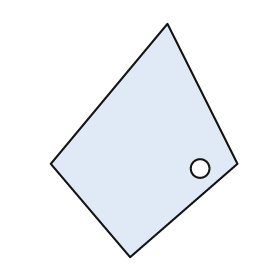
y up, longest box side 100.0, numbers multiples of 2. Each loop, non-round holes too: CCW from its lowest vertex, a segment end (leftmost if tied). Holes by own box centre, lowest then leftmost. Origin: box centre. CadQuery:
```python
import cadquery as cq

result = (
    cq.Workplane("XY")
    .moveTo(-6.0, -50.0)
    .lineTo(40.0, -10.0)
    .lineTo(10.0, 50.0)
    .lineTo(-40.0, -10.0)
    .close()
    .moveTo(24.0, -12.0)
    .circle(4.0)
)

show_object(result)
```